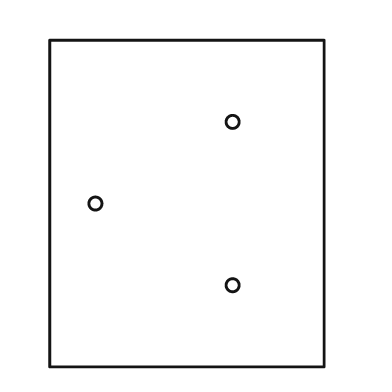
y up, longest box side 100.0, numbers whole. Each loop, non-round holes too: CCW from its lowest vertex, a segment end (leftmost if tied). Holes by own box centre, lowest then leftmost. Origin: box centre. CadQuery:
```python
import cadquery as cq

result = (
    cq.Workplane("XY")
    .moveTo(-42.0, -50.0)
    .lineTo(42.0, -50.0)
    .lineTo(42.0, 50.0)
    .lineTo(-42.0, 50.0)
    .close()
    .moveTo(14.0, -25.0)
    .circle(2.0)
    .moveTo(-28.0, 0.0)
    .circle(2.0)
    .moveTo(14.0, 25.0)
    .circle(2.0)
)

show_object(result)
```